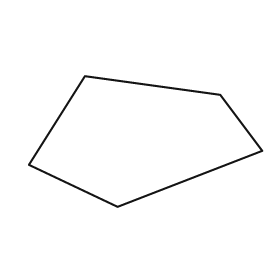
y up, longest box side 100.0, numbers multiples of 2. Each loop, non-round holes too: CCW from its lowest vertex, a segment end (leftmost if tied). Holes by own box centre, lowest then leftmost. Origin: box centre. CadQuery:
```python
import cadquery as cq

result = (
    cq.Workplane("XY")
    .moveTo(-12.0, -28.0)
    .lineTo(50.0, -4.0)
    .lineTo(32.0, 20.0)
    .lineTo(-26.0, 28.0)
    .lineTo(-50.0, -10.0)
    .close()
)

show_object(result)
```